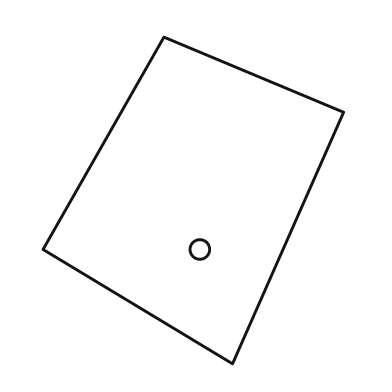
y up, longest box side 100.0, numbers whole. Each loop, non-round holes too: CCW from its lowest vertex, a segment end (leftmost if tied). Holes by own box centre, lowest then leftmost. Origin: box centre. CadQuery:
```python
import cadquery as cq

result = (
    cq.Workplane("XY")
    .moveTo(12.0, -50.0)
    .lineTo(46.0, 27.0)
    .lineTo(-9.0, 50.0)
    .lineTo(-46.0, -15.0)
    .close()
    .moveTo(2.0, -15.0)
    .circle(3.0)
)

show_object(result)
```